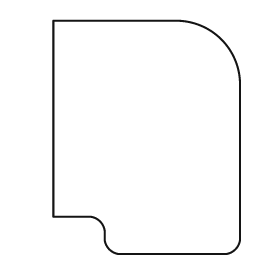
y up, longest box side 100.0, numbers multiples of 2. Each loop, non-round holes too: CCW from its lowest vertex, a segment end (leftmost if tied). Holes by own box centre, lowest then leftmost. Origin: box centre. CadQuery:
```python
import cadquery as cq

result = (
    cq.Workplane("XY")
    .moveTo(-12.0, -50.0)
    .lineTo(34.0, -50.0)
    .threePointArc((38.0, -48.0), (40.0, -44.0))
    .lineTo(40.0, 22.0)
    .threePointArc((32.0, 42.0), (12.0, 50.0))
    .lineTo(-40.0, 50.0)
    .lineTo(-40.0, -34.0)
    .lineTo(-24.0, -34.0)
    .threePointArc((-20.0, -36.0), (-18.0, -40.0))
    .lineTo(-18.0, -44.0)
    .threePointArc((-16.0, -48.0), (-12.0, -50.0))
    .close()
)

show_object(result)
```